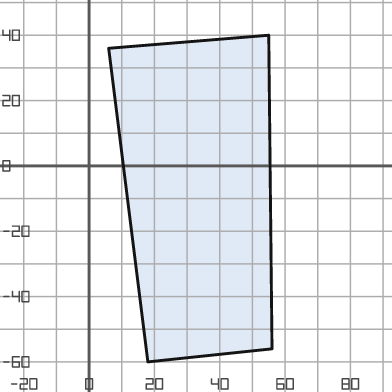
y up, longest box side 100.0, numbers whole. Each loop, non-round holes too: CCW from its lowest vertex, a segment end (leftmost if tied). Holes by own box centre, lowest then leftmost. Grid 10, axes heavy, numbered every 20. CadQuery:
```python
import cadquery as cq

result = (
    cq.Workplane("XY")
    .moveTo(18.0, -60.0)
    .lineTo(56.0, -56.0)
    .lineTo(55.0, 40.0)
    .lineTo(6.0, 36.0)
    .close()
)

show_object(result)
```